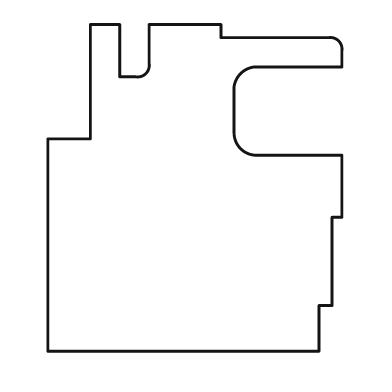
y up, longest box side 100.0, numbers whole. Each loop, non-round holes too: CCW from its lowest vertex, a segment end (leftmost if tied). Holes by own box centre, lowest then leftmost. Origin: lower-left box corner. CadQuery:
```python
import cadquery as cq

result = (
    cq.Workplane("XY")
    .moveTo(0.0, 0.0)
    .lineTo(83.0, 0.0)
    .lineTo(83.0, 14.0)
    .lineTo(87.0, 14.0)
    .lineTo(87.0, 41.0)
    .lineTo(90.0, 41.0)
    .lineTo(90.0, 60.0)
    .lineTo(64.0, 60.0)
    .threePointArc((59.0, 62.0), (57.0, 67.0))
    .lineTo(57.0, 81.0)
    .threePointArc((59.0, 85.0), (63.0, 87.0))
    .lineTo(90.0, 87.0)
    .lineTo(90.0, 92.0)
    .threePointArc((89.0, 95.0), (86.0, 96.0))
    .lineTo(53.0, 96.0)
    .lineTo(53.0, 100.0)
    .lineTo(31.0, 100.0)
    .lineTo(31.0, 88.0)
    .threePointArc((30.0, 85.0), (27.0, 84.0))
    .lineTo(22.0, 84.0)
    .lineTo(22.0, 100.0)
    .lineTo(13.0, 100.0)
    .lineTo(13.0, 65.0)
    .lineTo(0.0, 65.0)
    .close()
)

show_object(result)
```